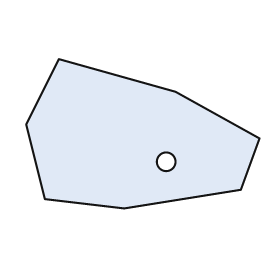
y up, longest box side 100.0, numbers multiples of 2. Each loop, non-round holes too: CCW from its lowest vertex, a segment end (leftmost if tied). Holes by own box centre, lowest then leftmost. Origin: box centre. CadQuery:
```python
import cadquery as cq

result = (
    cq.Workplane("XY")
    .moveTo(-8.0, -32.0)
    .lineTo(42.0, -24.0)
    .lineTo(50.0, -2.0)
    .lineTo(14.0, 18.0)
    .lineTo(-36.0, 32.0)
    .lineTo(-50.0, 4.0)
    .lineTo(-42.0, -28.0)
    .close()
    .moveTo(10.0, -12.0)
    .circle(4.0)
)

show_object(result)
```